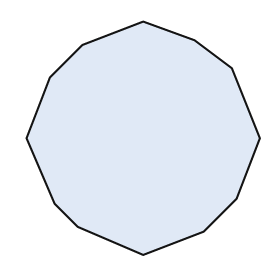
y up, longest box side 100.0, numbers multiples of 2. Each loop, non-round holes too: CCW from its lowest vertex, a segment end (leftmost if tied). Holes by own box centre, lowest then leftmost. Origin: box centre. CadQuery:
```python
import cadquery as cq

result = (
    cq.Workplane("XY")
    .moveTo(0.0, -50.0)
    .lineTo(26.0, -40.0)
    .lineTo(40.0, -26.0)
    .lineTo(50.0, 0.0)
    .lineTo(38.0, 30.0)
    .lineTo(22.0, 42.0)
    .lineTo(0.0, 50.0)
    .lineTo(-26.0, 40.0)
    .lineTo(-40.0, 26.0)
    .lineTo(-50.0, 0.0)
    .lineTo(-38.0, -28.0)
    .lineTo(-28.0, -38.0)
    .close()
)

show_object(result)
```